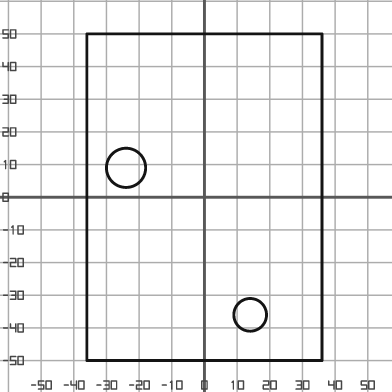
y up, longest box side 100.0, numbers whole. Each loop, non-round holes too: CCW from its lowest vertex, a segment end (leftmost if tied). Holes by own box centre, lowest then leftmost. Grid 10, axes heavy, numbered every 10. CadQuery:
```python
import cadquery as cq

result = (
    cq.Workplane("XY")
    .moveTo(-36.0, -50.0)
    .lineTo(36.0, -50.0)
    .lineTo(36.0, 50.0)
    .lineTo(-36.0, 50.0)
    .close()
    .moveTo(14.0, -36.0)
    .circle(5.0)
    .moveTo(-24.0, 9.0)
    .circle(6.0)
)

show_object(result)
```